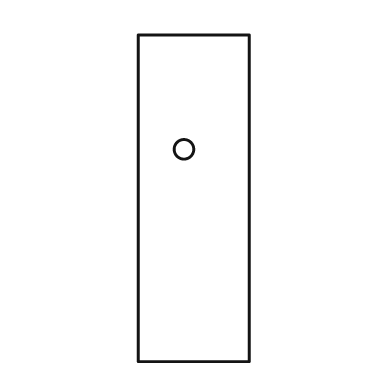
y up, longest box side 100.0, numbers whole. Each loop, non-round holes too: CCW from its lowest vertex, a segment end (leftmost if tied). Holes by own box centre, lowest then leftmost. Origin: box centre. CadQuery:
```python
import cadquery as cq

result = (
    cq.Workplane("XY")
    .moveTo(-17.0, -50.0)
    .lineTo(17.0, -50.0)
    .lineTo(17.0, 50.0)
    .lineTo(-17.0, 50.0)
    .close()
    .moveTo(-3.0, 15.0)
    .circle(3.0)
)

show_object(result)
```